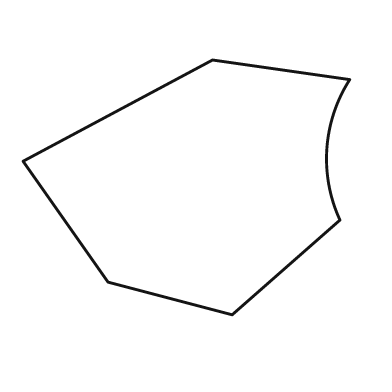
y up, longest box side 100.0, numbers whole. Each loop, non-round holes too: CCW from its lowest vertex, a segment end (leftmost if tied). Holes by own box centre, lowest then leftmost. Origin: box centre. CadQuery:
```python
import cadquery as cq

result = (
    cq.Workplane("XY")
    .moveTo(14.0, -39.0)
    .lineTo(47.0, -10.0)
    .threePointArc((43.0, 12.0), (50.0, 33.0))
    .lineTo(8.0, 39.0)
    .lineTo(-50.0, 8.0)
    .lineTo(-24.0, -29.0)
    .close()
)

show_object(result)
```